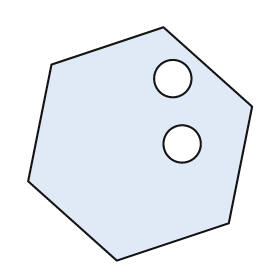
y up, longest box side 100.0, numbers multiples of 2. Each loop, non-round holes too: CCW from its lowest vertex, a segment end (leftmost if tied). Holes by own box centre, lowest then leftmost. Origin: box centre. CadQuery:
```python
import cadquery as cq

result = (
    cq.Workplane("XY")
    .moveTo(-10.0, -50.0)
    .lineTo(38.0, -34.0)
    .lineTo(48.0, 16.0)
    .lineTo(10.0, 50.0)
    .lineTo(-38.0, 34.0)
    .lineTo(-48.0, -16.0)
    .close()
    .moveTo(18.0, 0.0)
    .circle(8.0)
    .moveTo(14.0, 28.0)
    .circle(8.0)
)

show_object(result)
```